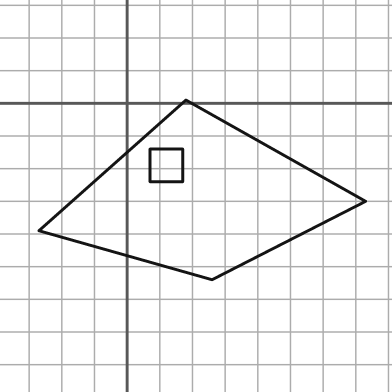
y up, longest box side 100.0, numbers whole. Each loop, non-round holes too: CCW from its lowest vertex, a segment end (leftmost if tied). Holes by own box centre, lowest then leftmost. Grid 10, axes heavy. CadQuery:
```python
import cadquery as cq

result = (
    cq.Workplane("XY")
    .moveTo(26.0, -54.0)
    .lineTo(73.0, -30.0)
    .lineTo(18.0, 1.0)
    .lineTo(-27.0, -39.0)
    .close()
    .moveTo(7.0, -24.0)
    .lineTo(17.0, -24.0)
    .lineTo(17.0, -14.0)
    .lineTo(7.0, -14.0)
    .close()
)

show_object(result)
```